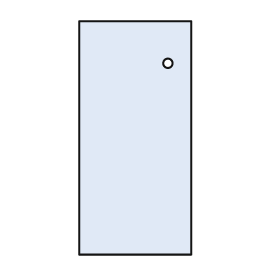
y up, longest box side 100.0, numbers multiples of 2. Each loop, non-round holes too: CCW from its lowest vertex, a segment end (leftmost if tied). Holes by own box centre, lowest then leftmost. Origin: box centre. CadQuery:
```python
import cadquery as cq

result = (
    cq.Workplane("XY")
    .moveTo(-24.0, -50.0)
    .lineTo(24.0, -50.0)
    .lineTo(24.0, 50.0)
    .lineTo(-24.0, 50.0)
    .close()
    .moveTo(14.0, 32.0)
    .circle(2.0)
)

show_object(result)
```